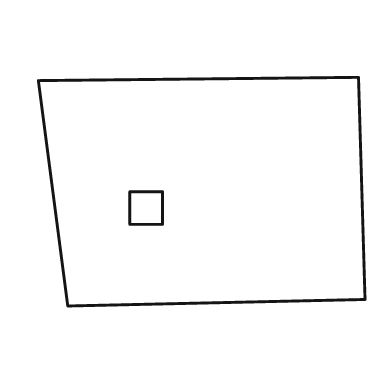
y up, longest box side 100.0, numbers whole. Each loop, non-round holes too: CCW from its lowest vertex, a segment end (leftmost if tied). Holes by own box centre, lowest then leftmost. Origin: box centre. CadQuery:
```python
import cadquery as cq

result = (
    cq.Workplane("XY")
    .moveTo(-41.0, -35.0)
    .lineTo(50.0, -33.0)
    .lineTo(48.0, 35.0)
    .lineTo(-50.0, 34.0)
    .close()
    .moveTo(-22.0, -10.0)
    .lineTo(-12.0, -10.0)
    .lineTo(-12.0, 0.0)
    .lineTo(-22.0, 0.0)
    .close()
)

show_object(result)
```